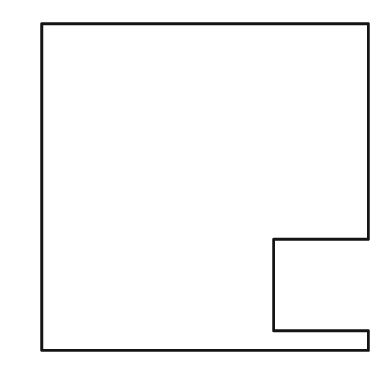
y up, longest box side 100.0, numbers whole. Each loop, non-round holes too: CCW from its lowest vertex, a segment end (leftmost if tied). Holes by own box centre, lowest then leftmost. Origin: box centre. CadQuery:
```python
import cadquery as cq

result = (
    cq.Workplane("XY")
    .moveTo(-50.0, -50.0)
    .lineTo(50.0, -50.0)
    .lineTo(50.0, -44.0)
    .lineTo(21.0, -44.0)
    .lineTo(21.0, -16.0)
    .lineTo(50.0, -16.0)
    .lineTo(50.0, 50.0)
    .lineTo(-50.0, 50.0)
    .close()
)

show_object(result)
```